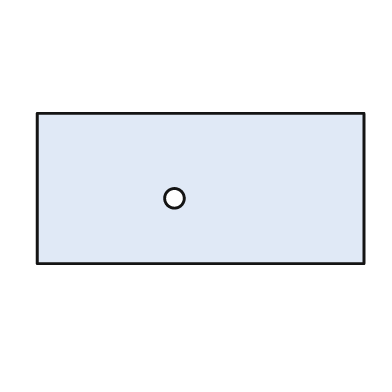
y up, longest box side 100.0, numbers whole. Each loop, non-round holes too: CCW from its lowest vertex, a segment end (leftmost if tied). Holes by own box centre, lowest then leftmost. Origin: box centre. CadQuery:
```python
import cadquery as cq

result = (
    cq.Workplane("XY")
    .moveTo(-50.0, -23.0)
    .lineTo(50.0, -23.0)
    .lineTo(50.0, 23.0)
    .lineTo(-50.0, 23.0)
    .close()
    .moveTo(-8.0, -3.0)
    .circle(3.0)
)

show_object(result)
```